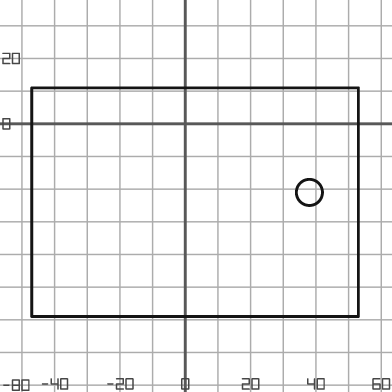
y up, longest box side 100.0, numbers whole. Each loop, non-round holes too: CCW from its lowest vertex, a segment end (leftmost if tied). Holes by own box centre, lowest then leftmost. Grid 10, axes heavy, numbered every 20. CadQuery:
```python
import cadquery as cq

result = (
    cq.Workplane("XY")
    .moveTo(-47.0, -59.0)
    .lineTo(53.0, -59.0)
    .lineTo(53.0, 11.0)
    .lineTo(-47.0, 11.0)
    .close()
    .moveTo(38.0, -21.0)
    .circle(4.0)
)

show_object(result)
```